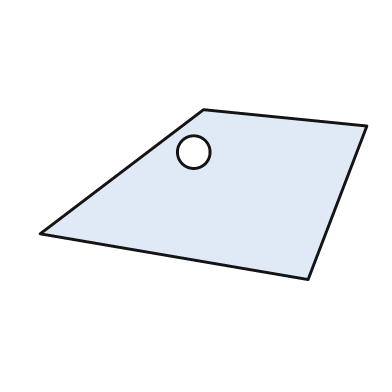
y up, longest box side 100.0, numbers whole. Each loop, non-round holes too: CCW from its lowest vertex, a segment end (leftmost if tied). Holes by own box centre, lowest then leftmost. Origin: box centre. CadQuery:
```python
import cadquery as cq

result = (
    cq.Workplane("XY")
    .moveTo(32.0, -26.0)
    .lineTo(50.0, 21.0)
    .lineTo(0.0, 26.0)
    .lineTo(-50.0, -12.0)
    .close()
    .moveTo(-3.0, 13.0)
    .circle(5.0)
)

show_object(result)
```